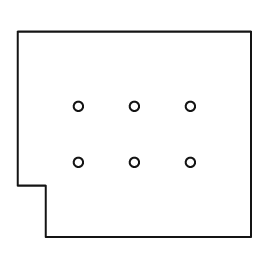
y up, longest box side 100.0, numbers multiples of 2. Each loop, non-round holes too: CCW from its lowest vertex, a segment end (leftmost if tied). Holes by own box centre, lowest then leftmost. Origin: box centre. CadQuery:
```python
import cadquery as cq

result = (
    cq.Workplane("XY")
    .moveTo(-38.0, -44.0)
    .lineTo(50.0, -44.0)
    .lineTo(50.0, 44.0)
    .lineTo(-50.0, 44.0)
    .lineTo(-50.0, -22.0)
    .lineTo(-38.0, -22.0)
    .close()
    .moveTo(-24.0, -12.0)
    .circle(2.0)
    .moveTo(0.0, -12.0)
    .circle(2.0)
    .moveTo(24.0, -12.0)
    .circle(2.0)
    .moveTo(-24.0, 12.0)
    .circle(2.0)
    .moveTo(0.0, 12.0)
    .circle(2.0)
    .moveTo(24.0, 12.0)
    .circle(2.0)
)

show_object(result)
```